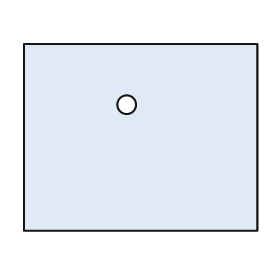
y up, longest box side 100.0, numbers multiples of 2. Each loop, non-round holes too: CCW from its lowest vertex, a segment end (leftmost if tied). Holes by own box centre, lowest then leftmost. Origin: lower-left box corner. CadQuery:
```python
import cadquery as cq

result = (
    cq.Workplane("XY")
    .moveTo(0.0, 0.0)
    .lineTo(100.0, 0.0)
    .lineTo(100.0, 80.0)
    .lineTo(0.0, 80.0)
    .close()
    .moveTo(44.0, 54.0)
    .circle(4.0)
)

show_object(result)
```